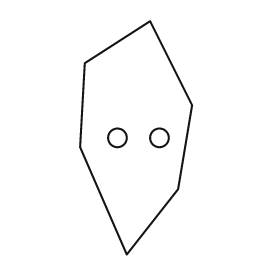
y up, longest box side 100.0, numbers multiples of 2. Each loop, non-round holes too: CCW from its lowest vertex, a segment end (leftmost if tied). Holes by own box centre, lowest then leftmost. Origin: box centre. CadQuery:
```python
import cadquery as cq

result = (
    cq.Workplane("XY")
    .moveTo(-4.0, -50.0)
    .lineTo(18.0, -22.0)
    .lineTo(24.0, 14.0)
    .lineTo(6.0, 50.0)
    .lineTo(-22.0, 32.0)
    .lineTo(-24.0, -4.0)
    .close()
    .moveTo(-8.0, 0.0)
    .circle(4.0)
    .moveTo(10.0, 0.0)
    .circle(4.0)
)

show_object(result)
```